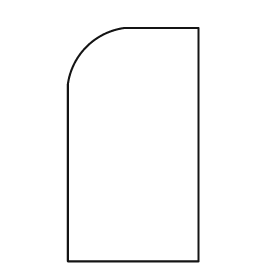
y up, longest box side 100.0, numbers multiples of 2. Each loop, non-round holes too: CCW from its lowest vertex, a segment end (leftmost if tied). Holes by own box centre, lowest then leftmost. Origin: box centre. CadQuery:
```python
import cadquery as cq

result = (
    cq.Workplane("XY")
    .moveTo(-28.0, -50.0)
    .lineTo(28.0, -50.0)
    .lineTo(28.0, 50.0)
    .lineTo(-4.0, 50.0)
    .threePointArc((-20.0, 42.0), (-28.0, 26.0))
    .close()
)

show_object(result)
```